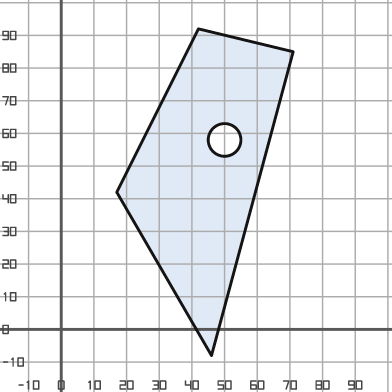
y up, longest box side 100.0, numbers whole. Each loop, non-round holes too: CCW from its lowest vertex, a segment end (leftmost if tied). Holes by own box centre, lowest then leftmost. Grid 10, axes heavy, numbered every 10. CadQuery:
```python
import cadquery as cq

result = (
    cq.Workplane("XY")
    .moveTo(46.0, -8.0)
    .lineTo(71.0, 85.0)
    .lineTo(42.0, 92.0)
    .lineTo(17.0, 42.0)
    .close()
    .moveTo(50.0, 58.0)
    .circle(5.0)
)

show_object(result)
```